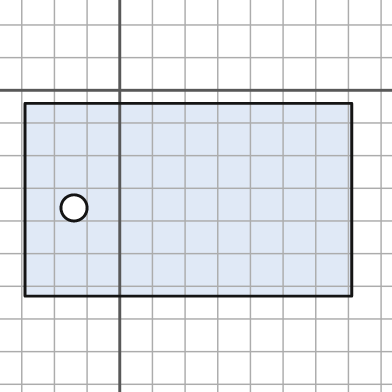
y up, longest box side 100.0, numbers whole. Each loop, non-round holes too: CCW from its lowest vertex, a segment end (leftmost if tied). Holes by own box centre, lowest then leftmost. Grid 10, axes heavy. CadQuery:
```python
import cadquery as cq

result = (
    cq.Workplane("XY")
    .moveTo(-29.0, -63.0)
    .lineTo(71.0, -63.0)
    .lineTo(71.0, -4.0)
    .lineTo(-29.0, -4.0)
    .close()
    .moveTo(-14.0, -36.0)
    .circle(4.0)
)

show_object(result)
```